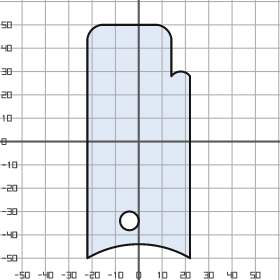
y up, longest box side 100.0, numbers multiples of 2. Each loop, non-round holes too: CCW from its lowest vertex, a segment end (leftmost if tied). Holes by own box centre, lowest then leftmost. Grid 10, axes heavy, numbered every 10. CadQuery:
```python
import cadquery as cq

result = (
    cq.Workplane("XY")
    .moveTo(-22.0, -50.0)
    .threePointArc((0.0, -44.0), (22.0, -50.0))
    .lineTo(22.0, 28.0)
    .threePointArc((18.0, 30.0), (14.0, 28.0))
    .lineTo(14.0, 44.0)
    .threePointArc((12.0, 48.0), (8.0, 50.0))
    .lineTo(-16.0, 50.0)
    .threePointArc((-20.0, 48.0), (-22.0, 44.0))
    .close()
    .moveTo(-4.0, -34.0)
    .circle(4.0)
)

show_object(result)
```